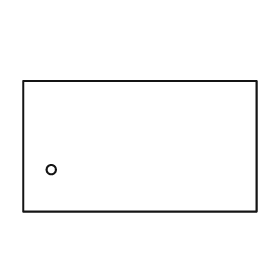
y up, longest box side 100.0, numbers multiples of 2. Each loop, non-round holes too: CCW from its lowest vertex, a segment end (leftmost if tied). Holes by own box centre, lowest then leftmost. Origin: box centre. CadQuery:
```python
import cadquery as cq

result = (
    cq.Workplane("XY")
    .moveTo(-50.0, -28.0)
    .lineTo(50.0, -28.0)
    .lineTo(50.0, 28.0)
    .lineTo(-50.0, 28.0)
    .close()
    .moveTo(-38.0, -10.0)
    .circle(2.0)
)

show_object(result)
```